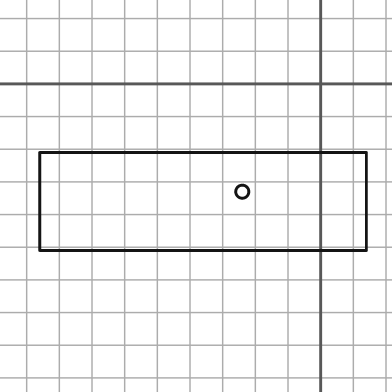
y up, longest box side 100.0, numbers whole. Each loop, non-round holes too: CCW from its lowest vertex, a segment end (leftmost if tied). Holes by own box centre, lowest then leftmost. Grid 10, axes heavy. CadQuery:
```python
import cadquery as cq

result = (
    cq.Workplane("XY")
    .moveTo(-86.0, -51.0)
    .lineTo(14.0, -51.0)
    .lineTo(14.0, -21.0)
    .lineTo(-86.0, -21.0)
    .close()
    .moveTo(-24.0, -33.0)
    .circle(2.0)
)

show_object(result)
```